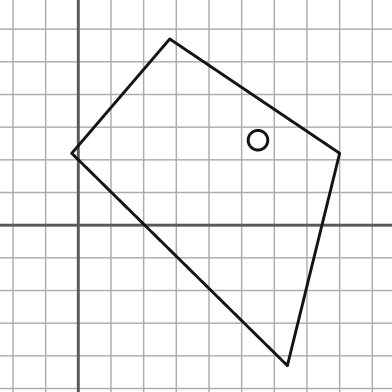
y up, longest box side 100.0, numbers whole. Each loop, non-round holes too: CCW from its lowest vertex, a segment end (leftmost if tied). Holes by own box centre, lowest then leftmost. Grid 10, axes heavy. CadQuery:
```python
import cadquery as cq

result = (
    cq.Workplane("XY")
    .moveTo(64.0, -43.0)
    .lineTo(80.0, 22.0)
    .lineTo(28.0, 57.0)
    .lineTo(-2.0, 22.0)
    .close()
    .moveTo(55.0, 26.0)
    .circle(3.0)
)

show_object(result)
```